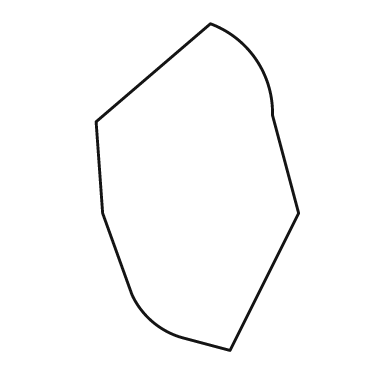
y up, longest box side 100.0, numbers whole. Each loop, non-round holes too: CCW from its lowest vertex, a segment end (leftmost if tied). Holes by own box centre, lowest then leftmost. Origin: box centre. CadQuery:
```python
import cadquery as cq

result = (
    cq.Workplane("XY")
    .moveTo(10.0, -50.0)
    .lineTo(31.0, -8.0)
    .lineTo(23.0, 22.0)
    .threePointArc((18.0, 39.0), (4.0, 50.0))
    .lineTo(-31.0, 20.0)
    .lineTo(-29.0, -8.0)
    .lineTo(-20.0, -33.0)
    .threePointArc((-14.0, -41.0), (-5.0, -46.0))
    .close()
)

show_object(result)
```